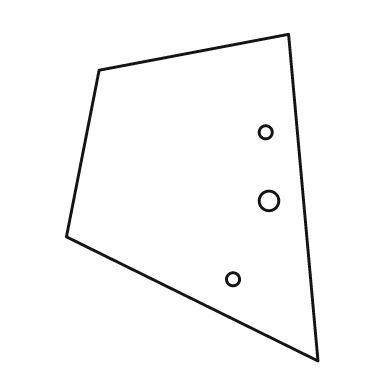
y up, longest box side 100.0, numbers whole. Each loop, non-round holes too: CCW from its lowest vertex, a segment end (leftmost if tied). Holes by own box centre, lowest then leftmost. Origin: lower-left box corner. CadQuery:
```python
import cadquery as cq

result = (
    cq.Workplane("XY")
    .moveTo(77.0, 0.0)
    .lineTo(68.0, 100.0)
    .lineTo(10.0, 89.0)
    .lineTo(0.0, 38.0)
    .close()
    .moveTo(51.0, 25.0)
    .circle(2.0)
    .moveTo(62.0, 49.0)
    .circle(3.0)
    .moveTo(61.0, 70.0)
    .circle(2.0)
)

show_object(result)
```